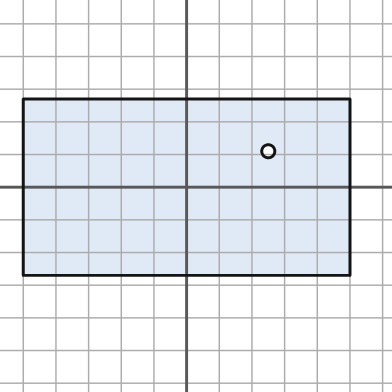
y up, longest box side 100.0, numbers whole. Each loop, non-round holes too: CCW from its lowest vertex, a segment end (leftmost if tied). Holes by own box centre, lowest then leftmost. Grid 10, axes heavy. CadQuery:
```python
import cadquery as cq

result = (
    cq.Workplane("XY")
    .moveTo(-50.0, -27.0)
    .lineTo(50.0, -27.0)
    .lineTo(50.0, 27.0)
    .lineTo(-50.0, 27.0)
    .close()
    .moveTo(25.0, 11.0)
    .circle(2.0)
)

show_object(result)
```